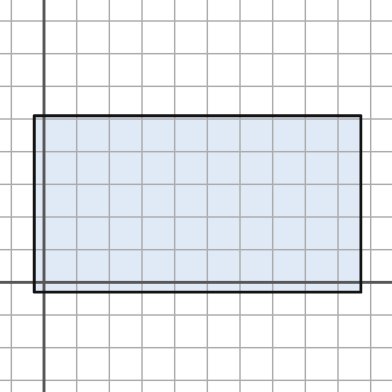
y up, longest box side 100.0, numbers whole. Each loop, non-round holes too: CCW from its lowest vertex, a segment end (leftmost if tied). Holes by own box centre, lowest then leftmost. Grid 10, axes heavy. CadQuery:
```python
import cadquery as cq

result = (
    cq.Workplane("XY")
    .moveTo(-3.0, -3.0)
    .lineTo(97.0, -3.0)
    .lineTo(97.0, 51.0)
    .lineTo(-3.0, 51.0)
    .close()
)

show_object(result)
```